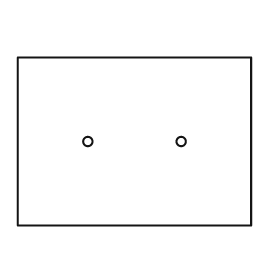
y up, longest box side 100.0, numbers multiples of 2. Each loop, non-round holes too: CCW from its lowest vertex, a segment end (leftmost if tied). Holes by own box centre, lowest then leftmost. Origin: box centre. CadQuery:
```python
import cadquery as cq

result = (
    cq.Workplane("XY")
    .moveTo(-50.0, -36.0)
    .lineTo(50.0, -36.0)
    .lineTo(50.0, 36.0)
    .lineTo(-50.0, 36.0)
    .close()
    .moveTo(-20.0, 0.0)
    .circle(2.0)
    .moveTo(20.0, 0.0)
    .circle(2.0)
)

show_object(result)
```